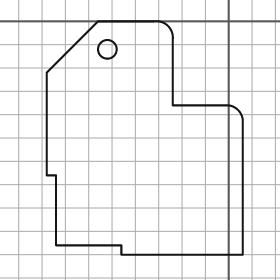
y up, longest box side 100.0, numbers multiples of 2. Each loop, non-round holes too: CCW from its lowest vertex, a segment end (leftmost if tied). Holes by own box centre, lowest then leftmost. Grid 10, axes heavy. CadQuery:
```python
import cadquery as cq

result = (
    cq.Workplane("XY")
    .moveTo(-46.0, -100.0)
    .lineTo(6.0, -100.0)
    .lineTo(6.0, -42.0)
    .threePointArc((4.0, -38.0), (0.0, -36.0))
    .lineTo(-24.0, -36.0)
    .lineTo(-24.0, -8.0)
    .threePointArc((-26.0, -2.0), (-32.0, 0.0))
    .lineTo(-56.0, 0.0)
    .lineTo(-78.0, -22.0)
    .lineTo(-78.0, -66.0)
    .lineTo(-74.0, -66.0)
    .lineTo(-74.0, -96.0)
    .lineTo(-46.0, -96.0)
    .close()
    .moveTo(-52.0, -12.0)
    .circle(4.0)
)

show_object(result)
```